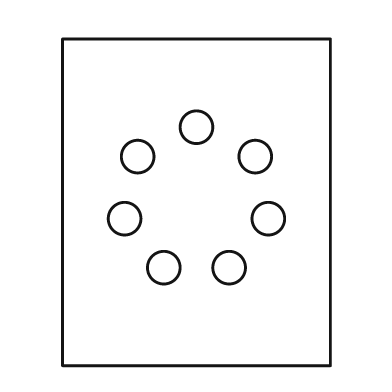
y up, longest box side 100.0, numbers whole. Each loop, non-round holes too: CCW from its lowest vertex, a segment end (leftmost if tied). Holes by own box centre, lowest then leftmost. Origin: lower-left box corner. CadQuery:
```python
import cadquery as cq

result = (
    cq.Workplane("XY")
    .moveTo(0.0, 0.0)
    .lineTo(82.0, 0.0)
    .lineTo(82.0, 100.0)
    .lineTo(0.0, 100.0)
    .close()
    .moveTo(31.0, 30.0)
    .circle(5.0)
    .moveTo(51.0, 30.0)
    .circle(5.0)
    .moveTo(19.0, 45.0)
    .circle(5.0)
    .moveTo(63.0, 45.0)
    .circle(5.0)
    .moveTo(23.0, 64.0)
    .circle(5.0)
    .moveTo(59.0, 64.0)
    .circle(5.0)
    .moveTo(41.0, 73.0)
    .circle(5.0)
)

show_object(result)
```